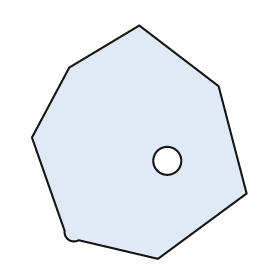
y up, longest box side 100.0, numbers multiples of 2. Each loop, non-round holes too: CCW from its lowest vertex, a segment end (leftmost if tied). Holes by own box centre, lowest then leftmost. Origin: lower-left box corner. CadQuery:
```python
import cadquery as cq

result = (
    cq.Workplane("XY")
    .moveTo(54.0, 0.0)
    .lineTo(92.0, 28.0)
    .lineTo(80.0, 74.0)
    .lineTo(46.0, 100.0)
    .lineTo(16.0, 82.0)
    .lineTo(0.0, 52.0)
    .lineTo(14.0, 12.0)
    .threePointArc((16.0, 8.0), (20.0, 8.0))
    .close()
    .moveTo(58.0, 42.0)
    .circle(6.0)
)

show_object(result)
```